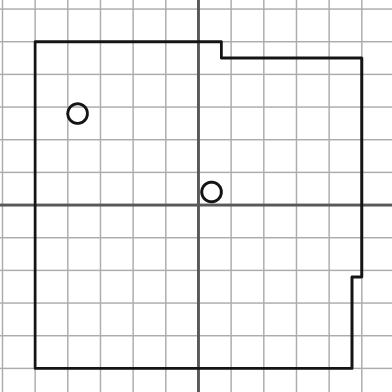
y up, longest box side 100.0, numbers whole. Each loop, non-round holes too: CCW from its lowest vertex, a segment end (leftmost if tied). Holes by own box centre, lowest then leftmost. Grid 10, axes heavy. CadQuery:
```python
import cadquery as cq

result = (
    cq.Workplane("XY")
    .moveTo(-50.0, -50.0)
    .lineTo(47.0, -50.0)
    .lineTo(47.0, -22.0)
    .lineTo(50.0, -22.0)
    .lineTo(50.0, 45.0)
    .lineTo(7.0, 45.0)
    .lineTo(7.0, 50.0)
    .lineTo(-50.0, 50.0)
    .close()
    .moveTo(4.0, 4.0)
    .circle(3.0)
    .moveTo(-37.0, 28.0)
    .circle(3.0)
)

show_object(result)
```